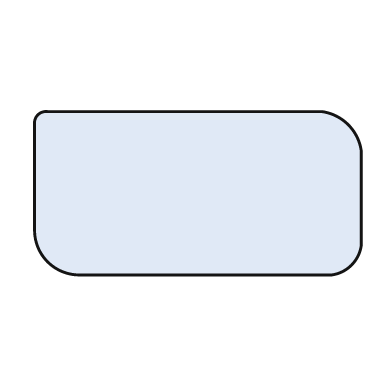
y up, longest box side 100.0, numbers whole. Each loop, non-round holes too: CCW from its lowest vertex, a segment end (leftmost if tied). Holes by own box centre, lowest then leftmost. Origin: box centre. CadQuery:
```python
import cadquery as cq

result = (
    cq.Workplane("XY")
    .moveTo(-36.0, -25.0)
    .lineTo(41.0, -25.0)
    .threePointArc((47.0, -22.0), (50.0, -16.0))
    .lineTo(50.0, 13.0)
    .threePointArc((46.0, 21.0), (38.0, 25.0))
    .lineTo(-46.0, 25.0)
    .threePointArc((-49.0, 24.0), (-50.0, 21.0))
    .lineTo(-50.0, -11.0)
    .threePointArc((-46.0, -21.0), (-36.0, -25.0))
    .close()
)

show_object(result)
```